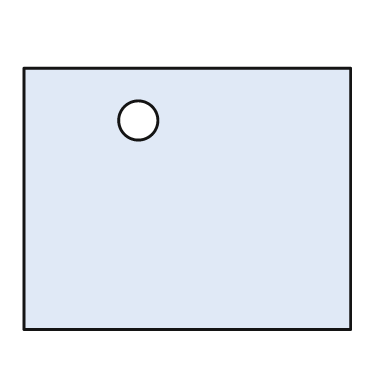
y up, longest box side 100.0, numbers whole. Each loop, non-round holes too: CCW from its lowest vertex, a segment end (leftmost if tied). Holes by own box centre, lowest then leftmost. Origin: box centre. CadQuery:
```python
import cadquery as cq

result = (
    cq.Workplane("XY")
    .moveTo(-50.0, -40.0)
    .lineTo(50.0, -40.0)
    .lineTo(50.0, 40.0)
    .lineTo(-50.0, 40.0)
    .close()
    .moveTo(-15.0, 24.0)
    .circle(6.0)
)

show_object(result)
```